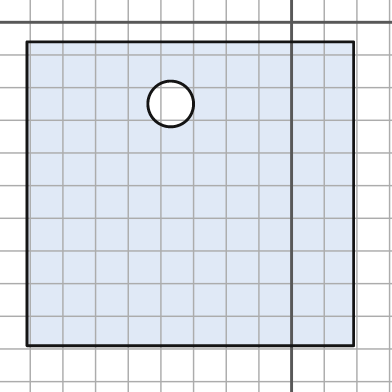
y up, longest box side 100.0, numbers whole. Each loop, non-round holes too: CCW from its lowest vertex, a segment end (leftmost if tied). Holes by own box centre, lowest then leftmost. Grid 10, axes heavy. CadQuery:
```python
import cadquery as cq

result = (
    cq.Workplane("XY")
    .moveTo(-81.0, -99.0)
    .lineTo(19.0, -99.0)
    .lineTo(19.0, -6.0)
    .lineTo(-81.0, -6.0)
    .close()
    .moveTo(-37.0, -25.0)
    .circle(7.0)
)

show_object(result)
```